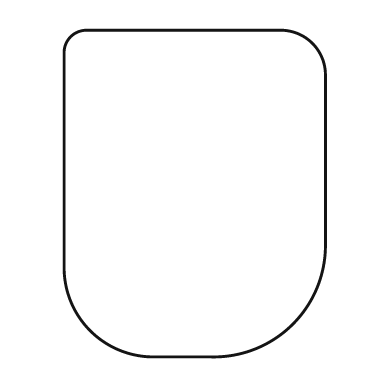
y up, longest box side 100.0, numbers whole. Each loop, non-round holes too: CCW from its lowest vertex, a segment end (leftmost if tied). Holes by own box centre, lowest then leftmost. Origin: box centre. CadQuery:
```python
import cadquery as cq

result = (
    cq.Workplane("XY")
    .moveTo(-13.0, -50.0)
    .lineTo(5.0, -50.0)
    .threePointArc((30.0, -40.0), (40.0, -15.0))
    .lineTo(40.0, 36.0)
    .threePointArc((36.0, 46.0), (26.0, 50.0))
    .lineTo(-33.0, 50.0)
    .threePointArc((-38.0, 48.0), (-40.0, 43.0))
    .lineTo(-40.0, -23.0)
    .threePointArc((-32.0, -42.0), (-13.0, -50.0))
    .close()
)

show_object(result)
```